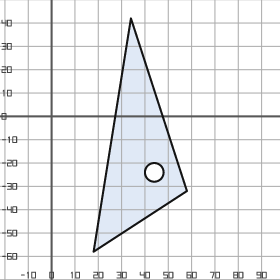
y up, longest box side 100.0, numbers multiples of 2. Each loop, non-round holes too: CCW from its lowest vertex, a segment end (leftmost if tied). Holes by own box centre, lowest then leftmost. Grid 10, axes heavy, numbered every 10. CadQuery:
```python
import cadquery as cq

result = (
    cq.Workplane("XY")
    .moveTo(18.0, -58.0)
    .lineTo(58.0, -32.0)
    .lineTo(34.0, 42.0)
    .close()
    .moveTo(44.0, -24.0)
    .circle(4.0)
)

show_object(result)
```